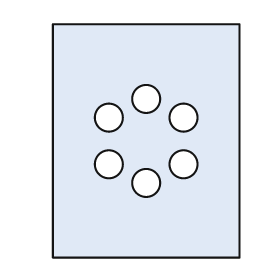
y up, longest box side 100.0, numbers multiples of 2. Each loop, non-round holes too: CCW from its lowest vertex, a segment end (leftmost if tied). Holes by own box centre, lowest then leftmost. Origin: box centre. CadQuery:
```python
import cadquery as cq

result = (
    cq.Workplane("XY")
    .moveTo(-40.0, -50.0)
    .lineTo(40.0, -50.0)
    .lineTo(40.0, 50.0)
    .lineTo(-40.0, 50.0)
    .close()
    .moveTo(0.0, -18.0)
    .circle(6.0)
    .moveTo(-16.0, -10.0)
    .circle(6.0)
    .moveTo(16.0, -10.0)
    .circle(6.0)
    .moveTo(-16.0, 10.0)
    .circle(6.0)
    .moveTo(16.0, 10.0)
    .circle(6.0)
    .moveTo(0.0, 18.0)
    .circle(6.0)
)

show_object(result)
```